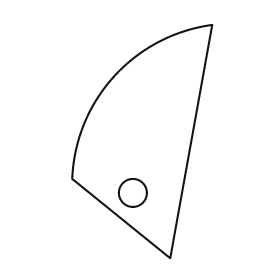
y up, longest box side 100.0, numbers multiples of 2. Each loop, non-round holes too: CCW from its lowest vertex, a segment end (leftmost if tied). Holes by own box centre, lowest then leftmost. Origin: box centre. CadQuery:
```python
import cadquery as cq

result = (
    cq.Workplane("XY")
    .moveTo(12.0, -50.0)
    .lineTo(30.0, 50.0)
    .threePointArc((-12.0, 28.0), (-30.0, -16.0))
    .close()
    .moveTo(-4.0, -22.0)
    .circle(6.0)
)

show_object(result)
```